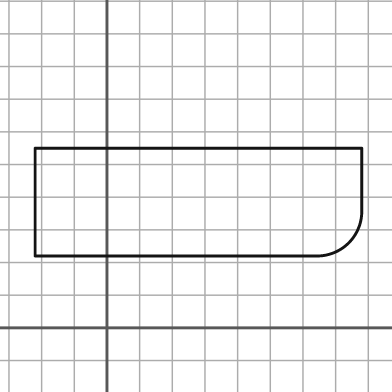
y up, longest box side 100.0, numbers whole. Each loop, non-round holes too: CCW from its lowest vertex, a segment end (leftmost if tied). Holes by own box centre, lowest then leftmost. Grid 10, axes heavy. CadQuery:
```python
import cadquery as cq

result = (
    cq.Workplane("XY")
    .moveTo(-22.0, 22.0)
    .lineTo(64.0, 22.0)
    .threePointArc((74.0, 26.0), (78.0, 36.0))
    .lineTo(78.0, 55.0)
    .lineTo(-22.0, 55.0)
    .close()
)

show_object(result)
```